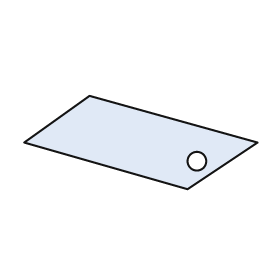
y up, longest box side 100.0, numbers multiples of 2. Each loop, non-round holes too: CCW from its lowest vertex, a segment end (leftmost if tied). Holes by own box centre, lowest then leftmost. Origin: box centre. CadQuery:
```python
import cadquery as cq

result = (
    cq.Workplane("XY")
    .moveTo(20.0, -20.0)
    .lineTo(50.0, 0.0)
    .lineTo(-22.0, 20.0)
    .lineTo(-50.0, 0.0)
    .close()
    .moveTo(24.0, -8.0)
    .circle(4.0)
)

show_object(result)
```